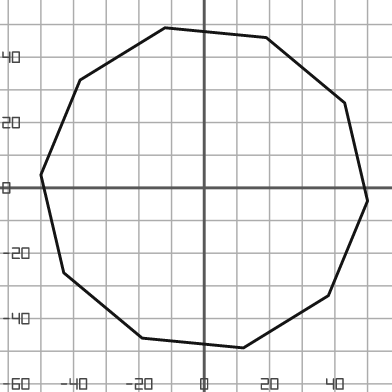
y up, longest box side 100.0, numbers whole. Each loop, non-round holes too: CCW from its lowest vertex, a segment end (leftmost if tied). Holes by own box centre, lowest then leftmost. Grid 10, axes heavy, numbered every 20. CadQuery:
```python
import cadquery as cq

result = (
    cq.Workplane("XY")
    .moveTo(12.0, -49.0)
    .lineTo(38.0, -33.0)
    .lineTo(50.0, -4.0)
    .lineTo(43.0, 26.0)
    .lineTo(19.0, 46.0)
    .lineTo(-12.0, 49.0)
    .lineTo(-38.0, 33.0)
    .lineTo(-50.0, 4.0)
    .lineTo(-43.0, -26.0)
    .lineTo(-19.0, -46.0)
    .close()
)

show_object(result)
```